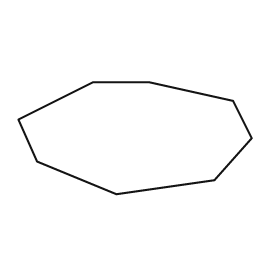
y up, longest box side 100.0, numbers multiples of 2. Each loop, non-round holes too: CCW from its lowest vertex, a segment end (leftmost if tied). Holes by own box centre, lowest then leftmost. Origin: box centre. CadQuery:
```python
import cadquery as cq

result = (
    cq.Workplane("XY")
    .moveTo(-8.0, -24.0)
    .lineTo(34.0, -18.0)
    .lineTo(50.0, 0.0)
    .lineTo(42.0, 16.0)
    .lineTo(6.0, 24.0)
    .lineTo(-18.0, 24.0)
    .lineTo(-50.0, 8.0)
    .lineTo(-42.0, -10.0)
    .close()
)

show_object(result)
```